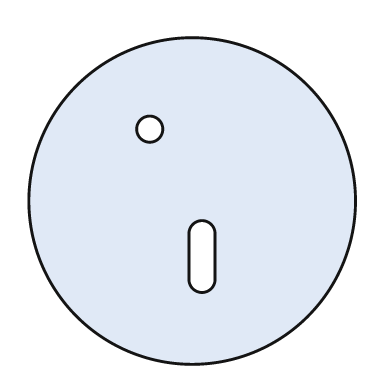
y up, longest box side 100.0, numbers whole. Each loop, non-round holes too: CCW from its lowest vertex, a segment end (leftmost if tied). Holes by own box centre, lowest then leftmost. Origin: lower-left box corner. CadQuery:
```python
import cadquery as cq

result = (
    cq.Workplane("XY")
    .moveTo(50.0, 50.0)
    .circle(50.0)
    .moveTo(49.0, 26.0)
    .threePointArc((53.0, 22.0), (57.0, 26.0))
    .lineTo(57.0, 40.0)
    .threePointArc((53.0, 44.0), (49.0, 40.0))
    .close()
    .moveTo(37.0, 72.0)
    .circle(4.0)
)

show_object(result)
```